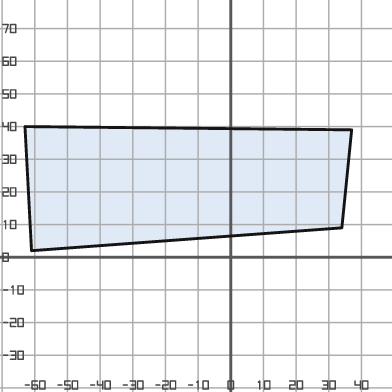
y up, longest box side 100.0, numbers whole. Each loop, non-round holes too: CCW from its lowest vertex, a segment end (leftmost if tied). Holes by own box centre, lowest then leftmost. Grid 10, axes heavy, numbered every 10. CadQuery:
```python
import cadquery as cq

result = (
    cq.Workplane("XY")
    .moveTo(-61.0, 2.0)
    .lineTo(34.0, 9.0)
    .lineTo(37.0, 39.0)
    .lineTo(-63.0, 40.0)
    .close()
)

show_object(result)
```